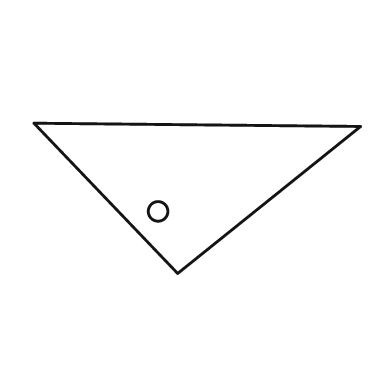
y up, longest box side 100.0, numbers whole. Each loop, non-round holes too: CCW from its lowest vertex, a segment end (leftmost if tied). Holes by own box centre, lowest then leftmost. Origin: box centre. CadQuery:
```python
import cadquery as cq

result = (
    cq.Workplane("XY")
    .moveTo(-6.0, -23.0)
    .lineTo(50.0, 22.0)
    .lineTo(-50.0, 23.0)
    .close()
    .moveTo(-12.0, -4.0)
    .circle(3.0)
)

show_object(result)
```